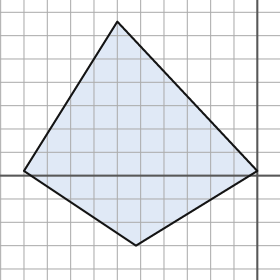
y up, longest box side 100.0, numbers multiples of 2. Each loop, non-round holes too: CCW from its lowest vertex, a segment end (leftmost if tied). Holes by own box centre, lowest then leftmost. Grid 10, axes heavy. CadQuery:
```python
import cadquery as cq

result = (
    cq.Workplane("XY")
    .moveTo(-52.0, -30.0)
    .lineTo(0.0, 2.0)
    .lineTo(-60.0, 66.0)
    .lineTo(-100.0, 2.0)
    .close()
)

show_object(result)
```